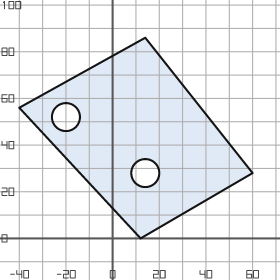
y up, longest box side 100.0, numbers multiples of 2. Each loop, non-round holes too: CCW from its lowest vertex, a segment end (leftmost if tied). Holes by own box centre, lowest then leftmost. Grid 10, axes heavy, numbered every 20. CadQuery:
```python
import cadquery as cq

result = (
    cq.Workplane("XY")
    .moveTo(12.0, 0.0)
    .lineTo(60.0, 28.0)
    .lineTo(14.0, 86.0)
    .lineTo(-40.0, 56.0)
    .close()
    .moveTo(14.0, 28.0)
    .circle(6.0)
    .moveTo(-20.0, 52.0)
    .circle(6.0)
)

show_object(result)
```